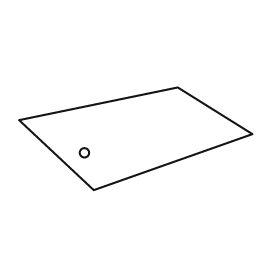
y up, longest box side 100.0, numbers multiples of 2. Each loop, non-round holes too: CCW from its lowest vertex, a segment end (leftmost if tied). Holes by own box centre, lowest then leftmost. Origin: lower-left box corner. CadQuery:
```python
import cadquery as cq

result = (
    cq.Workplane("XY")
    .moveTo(32.0, 0.0)
    .lineTo(100.0, 24.0)
    .lineTo(68.0, 44.0)
    .lineTo(0.0, 30.0)
    .close()
    .moveTo(28.0, 16.0)
    .circle(2.0)
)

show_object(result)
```